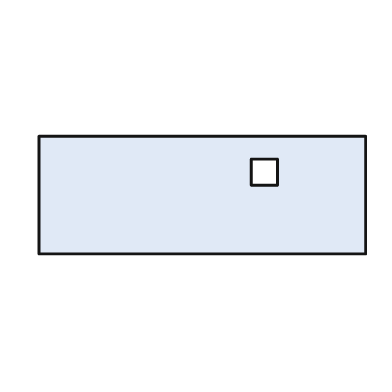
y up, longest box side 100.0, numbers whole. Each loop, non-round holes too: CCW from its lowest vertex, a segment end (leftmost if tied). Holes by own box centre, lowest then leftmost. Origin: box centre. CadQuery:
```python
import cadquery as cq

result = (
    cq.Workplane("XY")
    .moveTo(-50.0, -18.0)
    .lineTo(50.0, -18.0)
    .lineTo(50.0, 18.0)
    .lineTo(-50.0, 18.0)
    .close()
    .moveTo(15.0, 3.0)
    .lineTo(23.0, 3.0)
    .lineTo(23.0, 11.0)
    .lineTo(15.0, 11.0)
    .close()
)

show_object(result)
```